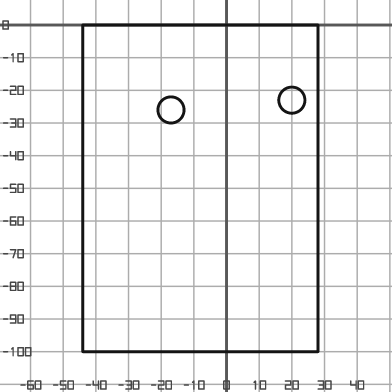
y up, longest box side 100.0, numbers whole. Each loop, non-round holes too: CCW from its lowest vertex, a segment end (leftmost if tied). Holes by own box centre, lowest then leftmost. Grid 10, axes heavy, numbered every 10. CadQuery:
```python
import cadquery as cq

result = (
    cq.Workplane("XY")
    .moveTo(-44.0, -100.0)
    .lineTo(28.0, -100.0)
    .lineTo(28.0, 0.0)
    .lineTo(-44.0, 0.0)
    .close()
    .moveTo(-17.0, -26.0)
    .circle(4.0)
    .moveTo(20.0, -23.0)
    .circle(4.0)
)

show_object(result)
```